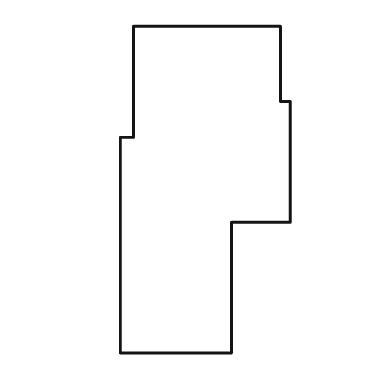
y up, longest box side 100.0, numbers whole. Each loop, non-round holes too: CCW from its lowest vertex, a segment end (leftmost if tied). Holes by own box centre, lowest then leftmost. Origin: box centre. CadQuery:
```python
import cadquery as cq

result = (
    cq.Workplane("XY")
    .moveTo(-26.0, -50.0)
    .lineTo(8.0, -50.0)
    .lineTo(8.0, -10.0)
    .lineTo(26.0, -10.0)
    .lineTo(26.0, 27.0)
    .lineTo(23.0, 27.0)
    .lineTo(23.0, 50.0)
    .lineTo(-22.0, 50.0)
    .lineTo(-22.0, 16.0)
    .lineTo(-26.0, 16.0)
    .close()
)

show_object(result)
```